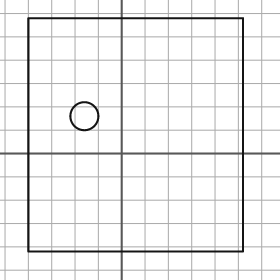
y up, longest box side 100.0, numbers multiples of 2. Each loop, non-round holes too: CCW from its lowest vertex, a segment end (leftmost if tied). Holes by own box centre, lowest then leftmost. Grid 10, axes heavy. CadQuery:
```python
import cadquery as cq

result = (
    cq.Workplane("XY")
    .moveTo(-40.0, -42.0)
    .lineTo(52.0, -42.0)
    .lineTo(52.0, 58.0)
    .lineTo(-40.0, 58.0)
    .close()
    .moveTo(-16.0, 16.0)
    .circle(6.0)
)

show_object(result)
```